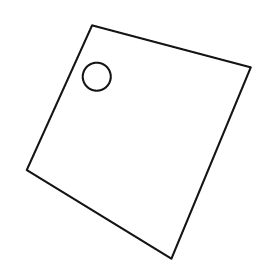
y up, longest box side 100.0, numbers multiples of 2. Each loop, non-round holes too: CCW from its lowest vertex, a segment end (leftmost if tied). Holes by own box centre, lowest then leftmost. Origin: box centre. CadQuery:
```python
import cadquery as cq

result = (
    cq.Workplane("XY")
    .moveTo(14.0, -50.0)
    .lineTo(48.0, 32.0)
    .lineTo(-20.0, 50.0)
    .lineTo(-48.0, -12.0)
    .close()
    .moveTo(-18.0, 28.0)
    .circle(6.0)
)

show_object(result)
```